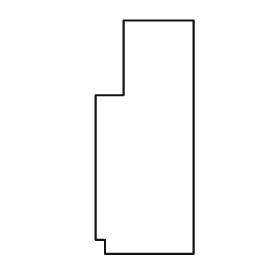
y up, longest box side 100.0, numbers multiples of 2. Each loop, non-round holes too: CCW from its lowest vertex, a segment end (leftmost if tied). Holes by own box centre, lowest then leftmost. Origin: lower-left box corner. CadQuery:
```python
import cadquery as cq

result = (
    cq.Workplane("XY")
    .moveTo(4.0, 0.0)
    .lineTo(42.0, 0.0)
    .lineTo(42.0, 100.0)
    .lineTo(12.0, 100.0)
    .lineTo(12.0, 68.0)
    .lineTo(0.0, 68.0)
    .lineTo(0.0, 6.0)
    .lineTo(4.0, 6.0)
    .close()
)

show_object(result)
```